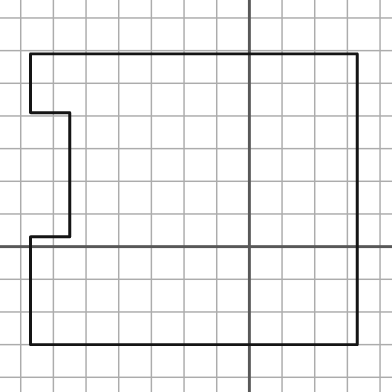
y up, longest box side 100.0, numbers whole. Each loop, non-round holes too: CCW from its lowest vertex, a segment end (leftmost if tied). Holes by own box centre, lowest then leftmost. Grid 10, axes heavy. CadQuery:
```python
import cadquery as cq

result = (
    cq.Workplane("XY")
    .moveTo(-67.0, -30.0)
    .lineTo(33.0, -30.0)
    .lineTo(33.0, 59.0)
    .lineTo(-67.0, 59.0)
    .lineTo(-67.0, 41.0)
    .lineTo(-55.0, 41.0)
    .lineTo(-55.0, 3.0)
    .lineTo(-67.0, 3.0)
    .close()
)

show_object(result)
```